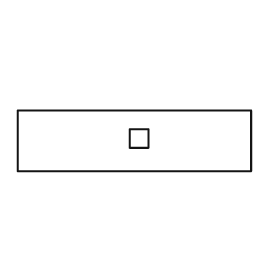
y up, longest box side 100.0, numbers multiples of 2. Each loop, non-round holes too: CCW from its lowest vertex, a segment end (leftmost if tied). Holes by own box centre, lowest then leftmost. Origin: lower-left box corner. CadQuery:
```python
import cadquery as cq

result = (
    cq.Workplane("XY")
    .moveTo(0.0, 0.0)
    .lineTo(100.0, 0.0)
    .lineTo(100.0, 26.0)
    .lineTo(0.0, 26.0)
    .close()
    .moveTo(48.0, 10.0)
    .lineTo(56.0, 10.0)
    .lineTo(56.0, 18.0)
    .lineTo(48.0, 18.0)
    .close()
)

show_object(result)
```